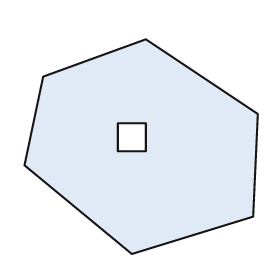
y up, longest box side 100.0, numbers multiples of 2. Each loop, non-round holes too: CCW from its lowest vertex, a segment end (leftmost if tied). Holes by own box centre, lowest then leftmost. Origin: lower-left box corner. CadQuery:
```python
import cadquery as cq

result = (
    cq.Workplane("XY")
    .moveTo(46.0, 0.0)
    .lineTo(98.0, 16.0)
    .lineTo(100.0, 60.0)
    .lineTo(52.0, 92.0)
    .lineTo(8.0, 76.0)
    .lineTo(0.0, 38.0)
    .close()
    .moveTo(40.0, 44.0)
    .lineTo(52.0, 44.0)
    .lineTo(52.0, 56.0)
    .lineTo(40.0, 56.0)
    .close()
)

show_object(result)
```